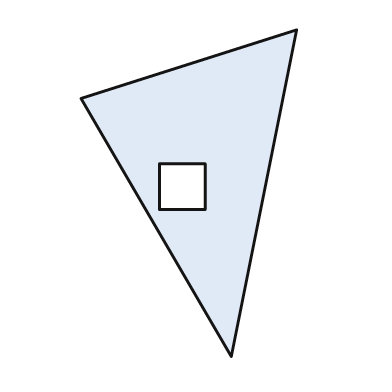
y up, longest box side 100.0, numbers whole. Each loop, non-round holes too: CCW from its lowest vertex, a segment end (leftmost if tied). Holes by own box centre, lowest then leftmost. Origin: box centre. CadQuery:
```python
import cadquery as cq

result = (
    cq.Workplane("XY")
    .moveTo(13.0, -50.0)
    .lineTo(33.0, 50.0)
    .lineTo(-33.0, 29.0)
    .close()
    .moveTo(-9.0, -5.0)
    .lineTo(5.0, -5.0)
    .lineTo(5.0, 9.0)
    .lineTo(-9.0, 9.0)
    .close()
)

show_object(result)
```